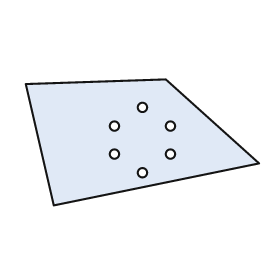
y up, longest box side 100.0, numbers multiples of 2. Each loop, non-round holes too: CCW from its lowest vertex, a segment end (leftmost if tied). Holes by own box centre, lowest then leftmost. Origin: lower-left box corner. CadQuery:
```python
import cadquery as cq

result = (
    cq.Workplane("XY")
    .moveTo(12.0, 0.0)
    .lineTo(100.0, 18.0)
    .lineTo(60.0, 54.0)
    .lineTo(0.0, 52.0)
    .close()
    .moveTo(50.0, 14.0)
    .circle(2.0)
    .moveTo(38.0, 22.0)
    .circle(2.0)
    .moveTo(62.0, 22.0)
    .circle(2.0)
    .moveTo(38.0, 34.0)
    .circle(2.0)
    .moveTo(62.0, 34.0)
    .circle(2.0)
    .moveTo(50.0, 42.0)
    .circle(2.0)
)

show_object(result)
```